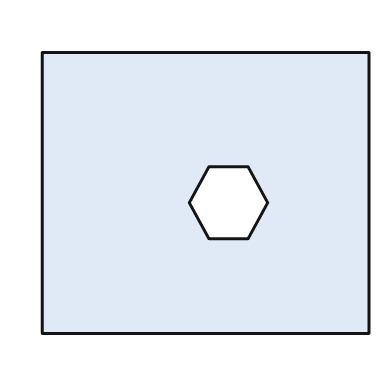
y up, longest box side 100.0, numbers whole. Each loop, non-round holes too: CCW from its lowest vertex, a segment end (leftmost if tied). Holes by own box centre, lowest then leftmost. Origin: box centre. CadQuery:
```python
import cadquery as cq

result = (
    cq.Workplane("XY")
    .moveTo(-50.0, -43.0)
    .lineTo(50.0, -43.0)
    .lineTo(50.0, 43.0)
    .lineTo(-50.0, 43.0)
    .close()
    .moveTo(1.0, -14.0)
    .lineTo(13.0, -14.0)
    .lineTo(19.0, -3.0)
    .lineTo(13.0, 8.0)
    .lineTo(1.0, 8.0)
    .lineTo(-5.0, -3.0)
    .close()
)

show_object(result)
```